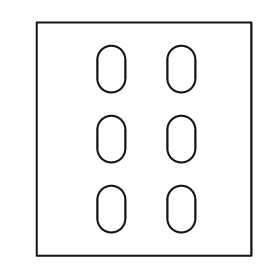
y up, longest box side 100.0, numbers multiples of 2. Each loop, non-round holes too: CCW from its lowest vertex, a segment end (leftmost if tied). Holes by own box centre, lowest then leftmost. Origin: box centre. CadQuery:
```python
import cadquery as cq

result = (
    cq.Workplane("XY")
    .moveTo(-46.0, -50.0)
    .lineTo(46.0, -50.0)
    .lineTo(46.0, 50.0)
    .lineTo(-46.0, 50.0)
    .close()
    .moveTo(-20.0, -34.0)
    .threePointArc((-14.0, -40.0), (-8.0, -34.0))
    .lineTo(-8.0, -26.0)
    .threePointArc((-14.0, -20.0), (-20.0, -26.0))
    .close()
    .moveTo(10.0, -34.0)
    .threePointArc((16.0, -40.0), (22.0, -34.0))
    .lineTo(22.0, -26.0)
    .threePointArc((16.0, -20.0), (10.0, -26.0))
    .close()
    .moveTo(-20.0, -4.0)
    .threePointArc((-14.0, -10.0), (-8.0, -4.0))
    .lineTo(-8.0, 4.0)
    .threePointArc((-14.0, 10.0), (-20.0, 4.0))
    .close()
    .moveTo(10.0, -4.0)
    .threePointArc((16.0, -10.0), (22.0, -4.0))
    .lineTo(22.0, 4.0)
    .threePointArc((16.0, 10.0), (10.0, 4.0))
    .close()
    .moveTo(-20.0, 26.0)
    .threePointArc((-14.0, 20.0), (-8.0, 26.0))
    .lineTo(-8.0, 34.0)
    .threePointArc((-14.0, 40.0), (-20.0, 34.0))
    .close()
    .moveTo(10.0, 26.0)
    .threePointArc((16.0, 20.0), (22.0, 26.0))
    .lineTo(22.0, 34.0)
    .threePointArc((16.0, 40.0), (10.0, 34.0))
    .close()
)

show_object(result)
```